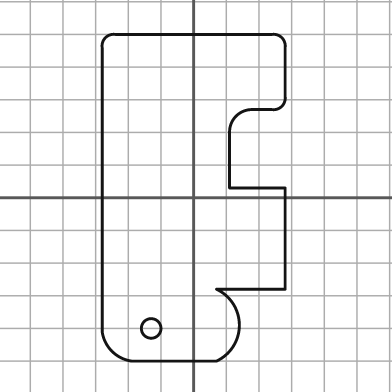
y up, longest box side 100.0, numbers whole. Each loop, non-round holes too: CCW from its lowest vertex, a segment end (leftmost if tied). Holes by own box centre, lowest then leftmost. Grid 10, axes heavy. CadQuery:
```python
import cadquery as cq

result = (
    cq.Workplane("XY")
    .moveTo(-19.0, -50.0)
    .lineTo(7.0, -50.0)
    .threePointArc((14.0, -39.0), (7.0, -28.0))
    .lineTo(28.0, -28.0)
    .lineTo(28.0, 3.0)
    .lineTo(11.0, 3.0)
    .lineTo(11.0, 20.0)
    .threePointArc((13.0, 25.0), (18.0, 27.0))
    .lineTo(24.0, 27.0)
    .threePointArc((27.0, 28.0), (28.0, 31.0))
    .lineTo(28.0, 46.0)
    .threePointArc((27.0, 49.0), (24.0, 50.0))
    .lineTo(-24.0, 50.0)
    .threePointArc((-27.0, 49.0), (-28.0, 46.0))
    .lineTo(-28.0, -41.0)
    .threePointArc((-25.0, -47.0), (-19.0, -50.0))
    .close()
    .moveTo(-13.0, -40.0)
    .circle(3.0)
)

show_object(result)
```